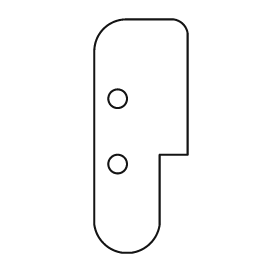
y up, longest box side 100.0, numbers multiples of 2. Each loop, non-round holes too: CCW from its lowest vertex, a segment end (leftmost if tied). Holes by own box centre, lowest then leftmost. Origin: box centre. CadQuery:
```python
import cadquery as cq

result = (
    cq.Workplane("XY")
    .moveTo(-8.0, -50.0)
    .lineTo(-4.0, -50.0)
    .threePointArc((4.0, -46.0), (8.0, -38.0))
    .lineTo(8.0, -8.0)
    .lineTo(20.0, -8.0)
    .lineTo(20.0, 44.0)
    .threePointArc((18.0, 48.0), (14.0, 50.0))
    .lineTo(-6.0, 50.0)
    .threePointArc((-16.0, 46.0), (-20.0, 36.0))
    .lineTo(-20.0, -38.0)
    .threePointArc((-16.0, -46.0), (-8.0, -50.0))
    .close()
    .moveTo(-10.0, -12.0)
    .circle(4.0)
    .moveTo(-10.0, 16.0)
    .circle(4.0)
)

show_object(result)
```